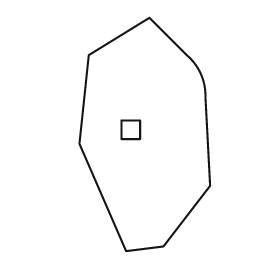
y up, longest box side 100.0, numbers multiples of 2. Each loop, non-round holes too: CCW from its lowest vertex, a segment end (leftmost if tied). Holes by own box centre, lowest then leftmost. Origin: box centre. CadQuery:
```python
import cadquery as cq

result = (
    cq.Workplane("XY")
    .moveTo(-8.0, -50.0)
    .lineTo(8.0, -48.0)
    .lineTo(28.0, -22.0)
    .lineTo(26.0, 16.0)
    .threePointArc((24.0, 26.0), (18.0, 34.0))
    .lineTo(2.0, 50.0)
    .lineTo(-24.0, 34.0)
    .lineTo(-28.0, -4.0)
    .close()
    .moveTo(-10.0, -2.0)
    .lineTo(-2.0, -2.0)
    .lineTo(-2.0, 6.0)
    .lineTo(-10.0, 6.0)
    .close()
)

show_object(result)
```